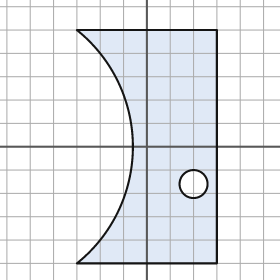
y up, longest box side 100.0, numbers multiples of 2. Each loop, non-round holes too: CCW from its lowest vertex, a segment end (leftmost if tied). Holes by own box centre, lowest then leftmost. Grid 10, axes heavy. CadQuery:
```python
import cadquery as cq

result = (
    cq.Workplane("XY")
    .moveTo(-30.0, -50.0)
    .lineTo(30.0, -50.0)
    .lineTo(30.0, 50.0)
    .lineTo(-30.0, 50.0)
    .threePointArc((-6.0, 0.0), (-30.0, -50.0))
    .close()
    .moveTo(20.0, -16.0)
    .circle(6.0)
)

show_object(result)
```